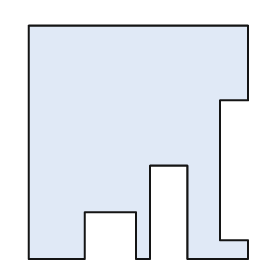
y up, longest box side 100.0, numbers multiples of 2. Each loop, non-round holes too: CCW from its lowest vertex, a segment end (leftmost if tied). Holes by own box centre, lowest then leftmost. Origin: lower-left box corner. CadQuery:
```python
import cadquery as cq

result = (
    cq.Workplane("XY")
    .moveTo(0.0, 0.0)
    .lineTo(24.0, 0.0)
    .lineTo(24.0, 20.0)
    .lineTo(46.0, 20.0)
    .lineTo(46.0, 0.0)
    .lineTo(52.0, 0.0)
    .lineTo(52.0, 40.0)
    .lineTo(68.0, 40.0)
    .lineTo(68.0, 0.0)
    .lineTo(94.0, 0.0)
    .lineTo(94.0, 8.0)
    .lineTo(82.0, 8.0)
    .lineTo(82.0, 68.0)
    .lineTo(94.0, 68.0)
    .lineTo(94.0, 100.0)
    .lineTo(0.0, 100.0)
    .close()
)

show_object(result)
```